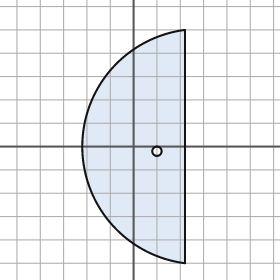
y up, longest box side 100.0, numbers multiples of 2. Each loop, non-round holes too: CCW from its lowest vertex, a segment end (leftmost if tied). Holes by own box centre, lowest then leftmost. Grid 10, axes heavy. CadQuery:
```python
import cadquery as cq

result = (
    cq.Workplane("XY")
    .moveTo(22.0, -50.0)
    .lineTo(22.0, 50.0)
    .threePointArc((-22.0, 0.0), (22.0, -50.0))
    .close()
    .moveTo(10.0, -2.0)
    .circle(2.0)
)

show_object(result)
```